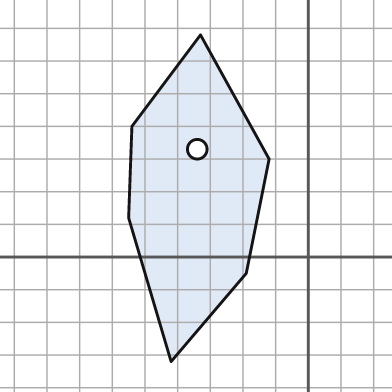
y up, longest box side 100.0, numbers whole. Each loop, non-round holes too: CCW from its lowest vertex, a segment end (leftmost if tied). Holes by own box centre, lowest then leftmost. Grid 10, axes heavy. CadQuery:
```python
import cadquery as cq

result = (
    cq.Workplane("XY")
    .moveTo(-42.0, -32.0)
    .lineTo(-19.0, -5.0)
    .lineTo(-12.0, 30.0)
    .lineTo(-33.0, 68.0)
    .lineTo(-54.0, 40.0)
    .lineTo(-55.0, 12.0)
    .close()
    .moveTo(-34.0, 33.0)
    .circle(3.0)
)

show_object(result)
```